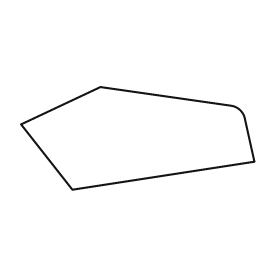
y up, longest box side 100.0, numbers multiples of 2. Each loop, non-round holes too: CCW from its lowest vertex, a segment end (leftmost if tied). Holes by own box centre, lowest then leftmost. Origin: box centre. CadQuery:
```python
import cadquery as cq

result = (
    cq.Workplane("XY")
    .moveTo(-28.0, -22.0)
    .lineTo(50.0, -10.0)
    .lineTo(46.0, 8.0)
    .threePointArc((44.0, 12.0), (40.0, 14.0))
    .lineTo(-16.0, 22.0)
    .lineTo(-50.0, 6.0)
    .close()
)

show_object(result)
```